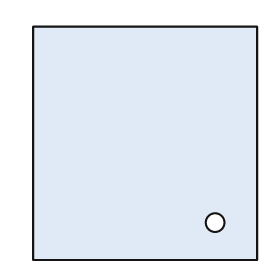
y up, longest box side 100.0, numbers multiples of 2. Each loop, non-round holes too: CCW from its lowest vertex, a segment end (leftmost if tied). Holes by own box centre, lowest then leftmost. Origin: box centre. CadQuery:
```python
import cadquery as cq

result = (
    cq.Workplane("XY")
    .moveTo(-48.0, -50.0)
    .lineTo(48.0, -50.0)
    .lineTo(48.0, 50.0)
    .lineTo(-48.0, 50.0)
    .close()
    .moveTo(30.0, -34.0)
    .circle(4.0)
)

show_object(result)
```